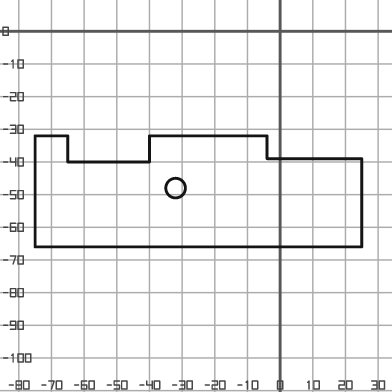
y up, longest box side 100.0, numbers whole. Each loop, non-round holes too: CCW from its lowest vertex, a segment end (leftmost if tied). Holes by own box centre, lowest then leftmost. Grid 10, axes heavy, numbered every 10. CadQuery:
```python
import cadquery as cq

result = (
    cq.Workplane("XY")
    .moveTo(-75.0, -66.0)
    .lineTo(25.0, -66.0)
    .lineTo(25.0, -39.0)
    .lineTo(-4.0, -39.0)
    .lineTo(-4.0, -32.0)
    .lineTo(-40.0, -32.0)
    .lineTo(-40.0, -40.0)
    .lineTo(-65.0, -40.0)
    .lineTo(-65.0, -32.0)
    .lineTo(-75.0, -32.0)
    .close()
    .moveTo(-32.0, -48.0)
    .circle(3.0)
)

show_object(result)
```